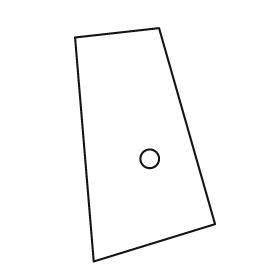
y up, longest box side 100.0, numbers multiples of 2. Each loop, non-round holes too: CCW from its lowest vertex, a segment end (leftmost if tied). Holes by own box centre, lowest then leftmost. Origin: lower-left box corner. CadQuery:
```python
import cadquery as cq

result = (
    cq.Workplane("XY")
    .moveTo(8.0, 0.0)
    .lineTo(60.0, 16.0)
    .lineTo(36.0, 100.0)
    .lineTo(0.0, 96.0)
    .close()
    .moveTo(32.0, 44.0)
    .circle(4.0)
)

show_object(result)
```